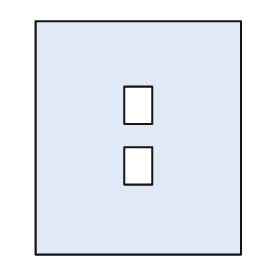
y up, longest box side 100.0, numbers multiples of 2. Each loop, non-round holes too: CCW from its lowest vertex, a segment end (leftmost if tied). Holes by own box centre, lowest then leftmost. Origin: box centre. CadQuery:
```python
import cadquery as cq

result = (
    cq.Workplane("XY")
    .moveTo(-44.0, -50.0)
    .lineTo(44.0, -50.0)
    .lineTo(44.0, 50.0)
    .lineTo(-44.0, 50.0)
    .close()
    .moveTo(-6.0, -20.0)
    .lineTo(6.0, -20.0)
    .lineTo(6.0, -4.0)
    .lineTo(-6.0, -4.0)
    .close()
    .moveTo(-6.0, 6.0)
    .lineTo(6.0, 6.0)
    .lineTo(6.0, 22.0)
    .lineTo(-6.0, 22.0)
    .close()
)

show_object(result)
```